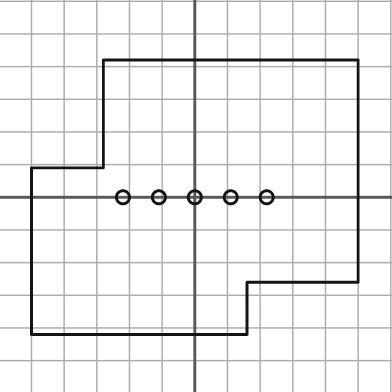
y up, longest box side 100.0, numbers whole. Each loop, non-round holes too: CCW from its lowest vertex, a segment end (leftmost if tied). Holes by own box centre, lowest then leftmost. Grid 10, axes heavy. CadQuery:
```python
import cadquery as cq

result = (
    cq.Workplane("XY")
    .moveTo(-50.0, -42.0)
    .lineTo(16.0, -42.0)
    .lineTo(16.0, -26.0)
    .lineTo(50.0, -26.0)
    .lineTo(50.0, 42.0)
    .lineTo(-28.0, 42.0)
    .lineTo(-28.0, 9.0)
    .lineTo(-50.0, 9.0)
    .close()
    .moveTo(-22.0, 0.0)
    .circle(2.0)
    .moveTo(-11.0, 0.0)
    .circle(2.0)
    .moveTo(0.0, 0.0)
    .circle(2.0)
    .moveTo(11.0, 0.0)
    .circle(2.0)
    .moveTo(22.0, 0.0)
    .circle(2.0)
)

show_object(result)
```